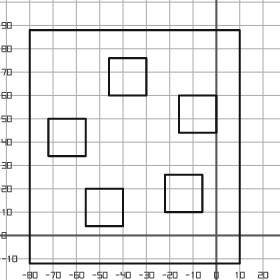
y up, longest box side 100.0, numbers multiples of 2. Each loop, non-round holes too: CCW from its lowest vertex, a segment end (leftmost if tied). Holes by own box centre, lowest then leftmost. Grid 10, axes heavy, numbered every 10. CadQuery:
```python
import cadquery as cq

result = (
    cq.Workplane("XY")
    .moveTo(-80.0, -12.0)
    .lineTo(10.0, -12.0)
    .lineTo(10.0, 88.0)
    .lineTo(-80.0, 88.0)
    .close()
    .moveTo(-56.0, 4.0)
    .lineTo(-40.0, 4.0)
    .lineTo(-40.0, 20.0)
    .lineTo(-56.0, 20.0)
    .close()
    .moveTo(-22.0, 10.0)
    .lineTo(-6.0, 10.0)
    .lineTo(-6.0, 26.0)
    .lineTo(-22.0, 26.0)
    .close()
    .moveTo(-72.0, 34.0)
    .lineTo(-56.0, 34.0)
    .lineTo(-56.0, 50.0)
    .lineTo(-72.0, 50.0)
    .close()
    .moveTo(-16.0, 44.0)
    .lineTo(0.0, 44.0)
    .lineTo(0.0, 60.0)
    .lineTo(-16.0, 60.0)
    .close()
    .moveTo(-46.0, 60.0)
    .lineTo(-30.0, 60.0)
    .lineTo(-30.0, 76.0)
    .lineTo(-46.0, 76.0)
    .close()
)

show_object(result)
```